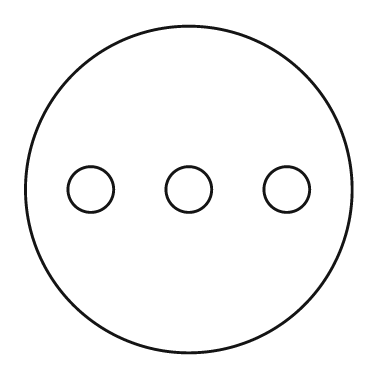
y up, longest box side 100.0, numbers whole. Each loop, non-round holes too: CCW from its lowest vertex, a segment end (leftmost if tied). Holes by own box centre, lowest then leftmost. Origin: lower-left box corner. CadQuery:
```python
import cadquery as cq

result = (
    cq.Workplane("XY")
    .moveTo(50.0, 50.0)
    .circle(50.0)
    .moveTo(20.0, 50.0)
    .circle(7.0)
    .moveTo(50.0, 50.0)
    .circle(7.0)
    .moveTo(80.0, 50.0)
    .circle(7.0)
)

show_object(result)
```